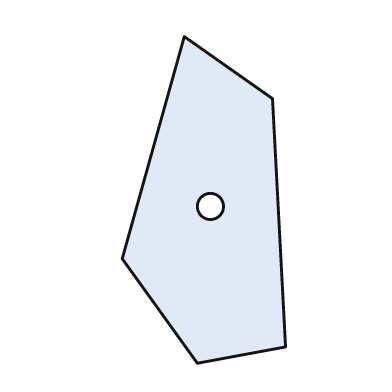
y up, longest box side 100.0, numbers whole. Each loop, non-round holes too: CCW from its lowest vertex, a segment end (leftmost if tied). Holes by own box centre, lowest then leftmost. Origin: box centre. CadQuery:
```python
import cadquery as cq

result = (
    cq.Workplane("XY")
    .moveTo(-2.0, -50.0)
    .lineTo(25.0, -45.0)
    .lineTo(21.0, 31.0)
    .lineTo(-6.0, 50.0)
    .lineTo(-25.0, -18.0)
    .close()
    .moveTo(2.0, -2.0)
    .circle(4.0)
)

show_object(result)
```